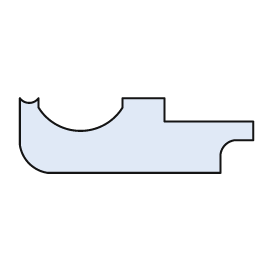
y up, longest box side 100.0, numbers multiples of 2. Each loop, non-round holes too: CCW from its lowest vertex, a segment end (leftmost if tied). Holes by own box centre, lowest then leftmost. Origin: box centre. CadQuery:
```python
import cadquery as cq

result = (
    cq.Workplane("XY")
    .moveTo(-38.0, -16.0)
    .lineTo(36.0, -16.0)
    .lineTo(36.0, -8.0)
    .threePointArc((38.0, -4.0), (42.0, -2.0))
    .lineTo(50.0, -2.0)
    .lineTo(50.0, 6.0)
    .lineTo(12.0, 6.0)
    .lineTo(12.0, 16.0)
    .lineTo(-6.0, 16.0)
    .lineTo(-6.0, 12.0)
    .threePointArc((-24.0, 2.0), (-42.0, 12.0))
    .lineTo(-42.0, 16.0)
    .threePointArc((-46.0, 14.0), (-50.0, 16.0))
    .lineTo(-50.0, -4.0)
    .threePointArc((-46.0, -12.0), (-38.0, -16.0))
    .close()
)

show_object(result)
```